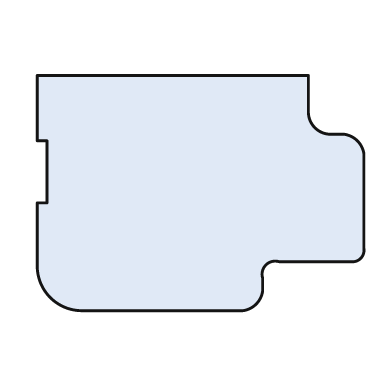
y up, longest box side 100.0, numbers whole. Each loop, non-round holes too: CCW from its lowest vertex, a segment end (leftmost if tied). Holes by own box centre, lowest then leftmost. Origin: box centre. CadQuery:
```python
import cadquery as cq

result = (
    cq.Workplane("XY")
    .moveTo(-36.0, -36.0)
    .lineTo(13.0, -36.0)
    .threePointArc((17.0, -34.0), (19.0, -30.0))
    .lineTo(19.0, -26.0)
    .threePointArc((20.0, -22.0), (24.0, -21.0))
    .lineTo(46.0, -21.0)
    .threePointArc((49.0, -20.0), (50.0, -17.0))
    .lineTo(50.0, 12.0)
    .threePointArc((48.0, 16.0), (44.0, 18.0))
    .lineTo(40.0, 18.0)
    .threePointArc((35.0, 20.0), (33.0, 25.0))
    .lineTo(33.0, 36.0)
    .lineTo(-50.0, 36.0)
    .lineTo(-50.0, 16.0)
    .lineTo(-47.0, 16.0)
    .lineTo(-47.0, -3.0)
    .lineTo(-50.0, -3.0)
    .lineTo(-50.0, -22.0)
    .threePointArc((-46.0, -32.0), (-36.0, -36.0))
    .close()
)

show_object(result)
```